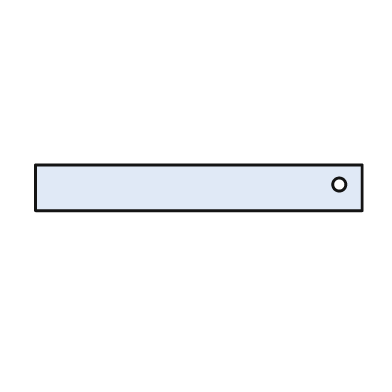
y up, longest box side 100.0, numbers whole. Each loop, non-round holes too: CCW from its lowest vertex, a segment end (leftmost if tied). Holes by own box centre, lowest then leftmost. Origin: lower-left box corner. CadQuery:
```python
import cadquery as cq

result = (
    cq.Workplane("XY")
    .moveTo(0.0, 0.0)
    .lineTo(100.0, 0.0)
    .lineTo(100.0, 14.0)
    .lineTo(0.0, 14.0)
    .close()
    .moveTo(93.0, 8.0)
    .circle(2.0)
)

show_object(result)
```